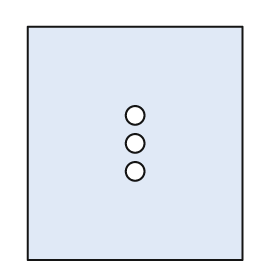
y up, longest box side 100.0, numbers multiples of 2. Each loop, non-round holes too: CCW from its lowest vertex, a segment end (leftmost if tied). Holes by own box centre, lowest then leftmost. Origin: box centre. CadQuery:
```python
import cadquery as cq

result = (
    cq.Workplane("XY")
    .moveTo(-46.0, -50.0)
    .lineTo(46.0, -50.0)
    .lineTo(46.0, 50.0)
    .lineTo(-46.0, 50.0)
    .close()
    .moveTo(0.0, -12.0)
    .circle(4.0)
    .moveTo(0.0, 0.0)
    .circle(4.0)
    .moveTo(0.0, 12.0)
    .circle(4.0)
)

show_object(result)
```